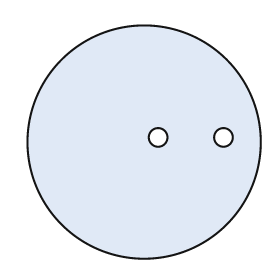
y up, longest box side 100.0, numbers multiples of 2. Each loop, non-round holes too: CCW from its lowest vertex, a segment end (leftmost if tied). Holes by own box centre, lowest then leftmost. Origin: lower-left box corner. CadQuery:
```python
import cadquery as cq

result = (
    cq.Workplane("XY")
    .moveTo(50.0, 50.0)
    .circle(50.0)
    .moveTo(56.0, 52.0)
    .circle(4.0)
    .moveTo(84.0, 52.0)
    .circle(4.0)
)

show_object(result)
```